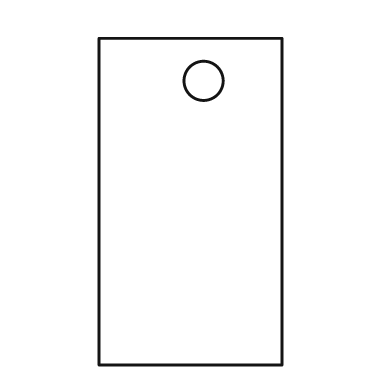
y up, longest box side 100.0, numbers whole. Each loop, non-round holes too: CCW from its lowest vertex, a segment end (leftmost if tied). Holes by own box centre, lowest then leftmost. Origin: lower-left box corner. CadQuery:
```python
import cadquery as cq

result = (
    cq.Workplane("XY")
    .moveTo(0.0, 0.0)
    .lineTo(56.0, 0.0)
    .lineTo(56.0, 100.0)
    .lineTo(0.0, 100.0)
    .close()
    .moveTo(32.0, 87.0)
    .circle(6.0)
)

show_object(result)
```